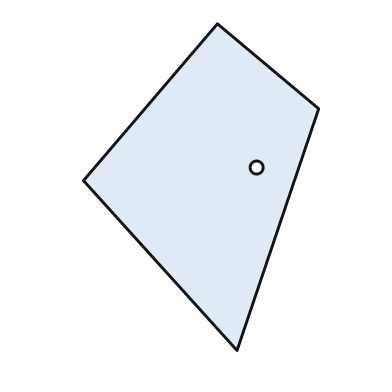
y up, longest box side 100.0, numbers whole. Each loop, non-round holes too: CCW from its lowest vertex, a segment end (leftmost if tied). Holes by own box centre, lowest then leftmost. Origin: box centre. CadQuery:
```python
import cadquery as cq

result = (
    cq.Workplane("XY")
    .moveTo(11.0, -50.0)
    .lineTo(36.0, 24.0)
    .lineTo(5.0, 50.0)
    .lineTo(-36.0, 2.0)
    .close()
    .moveTo(17.0, 6.0)
    .circle(2.0)
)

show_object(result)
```